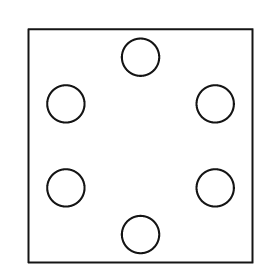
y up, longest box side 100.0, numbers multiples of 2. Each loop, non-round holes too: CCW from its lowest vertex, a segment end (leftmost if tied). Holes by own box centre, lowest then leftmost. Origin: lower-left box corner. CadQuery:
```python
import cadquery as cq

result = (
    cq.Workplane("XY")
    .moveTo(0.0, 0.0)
    .lineTo(96.0, 0.0)
    .lineTo(96.0, 100.0)
    .lineTo(0.0, 100.0)
    .close()
    .moveTo(48.0, 12.0)
    .circle(8.0)
    .moveTo(16.0, 32.0)
    .circle(8.0)
    .moveTo(80.0, 32.0)
    .circle(8.0)
    .moveTo(16.0, 68.0)
    .circle(8.0)
    .moveTo(80.0, 68.0)
    .circle(8.0)
    .moveTo(48.0, 88.0)
    .circle(8.0)
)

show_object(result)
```